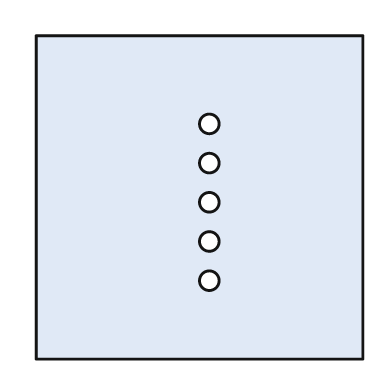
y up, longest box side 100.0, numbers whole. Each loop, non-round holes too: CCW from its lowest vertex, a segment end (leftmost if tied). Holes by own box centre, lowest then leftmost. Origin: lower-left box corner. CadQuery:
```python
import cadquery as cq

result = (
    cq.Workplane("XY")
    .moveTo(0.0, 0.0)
    .lineTo(100.0, 0.0)
    .lineTo(100.0, 99.0)
    .lineTo(0.0, 99.0)
    .close()
    .moveTo(53.0, 24.0)
    .circle(3.0)
    .moveTo(53.0, 36.0)
    .circle(3.0)
    .moveTo(53.0, 48.0)
    .circle(3.0)
    .moveTo(53.0, 60.0)
    .circle(3.0)
    .moveTo(53.0, 72.0)
    .circle(3.0)
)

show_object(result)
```